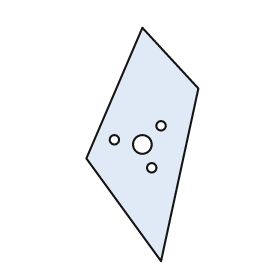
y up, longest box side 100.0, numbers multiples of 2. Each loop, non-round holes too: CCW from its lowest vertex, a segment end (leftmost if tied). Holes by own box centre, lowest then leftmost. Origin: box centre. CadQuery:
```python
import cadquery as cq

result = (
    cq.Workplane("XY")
    .moveTo(8.0, -50.0)
    .lineTo(24.0, 24.0)
    .lineTo(0.0, 50.0)
    .lineTo(-24.0, -6.0)
    .close()
    .moveTo(4.0, -10.0)
    .circle(2.0)
    .moveTo(0.0, 0.0)
    .circle(4.0)
    .moveTo(-12.0, 2.0)
    .circle(2.0)
    .moveTo(8.0, 8.0)
    .circle(2.0)
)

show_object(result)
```